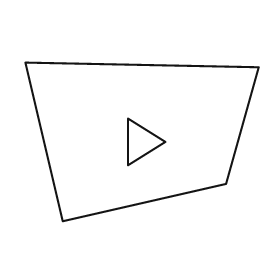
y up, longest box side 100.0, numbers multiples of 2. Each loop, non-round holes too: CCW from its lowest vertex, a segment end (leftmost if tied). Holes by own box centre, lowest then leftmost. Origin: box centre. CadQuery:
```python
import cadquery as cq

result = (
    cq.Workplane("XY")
    .moveTo(-34.0, -34.0)
    .lineTo(36.0, -18.0)
    .lineTo(50.0, 32.0)
    .lineTo(-50.0, 34.0)
    .close()
    .moveTo(-6.0, -10.0)
    .lineTo(10.0, 0.0)
    .lineTo(-6.0, 10.0)
    .close()
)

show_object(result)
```